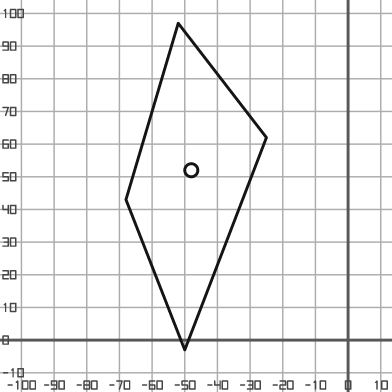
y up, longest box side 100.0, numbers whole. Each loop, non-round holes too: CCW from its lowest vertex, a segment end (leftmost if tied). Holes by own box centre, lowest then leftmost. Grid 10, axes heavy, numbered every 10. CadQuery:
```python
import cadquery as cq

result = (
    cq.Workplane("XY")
    .moveTo(-50.0, -3.0)
    .lineTo(-25.0, 62.0)
    .lineTo(-52.0, 97.0)
    .lineTo(-68.0, 43.0)
    .close()
    .moveTo(-48.0, 52.0)
    .circle(2.0)
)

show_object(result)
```